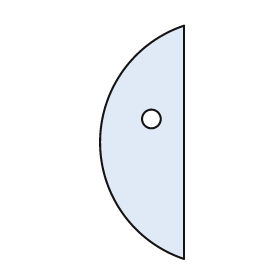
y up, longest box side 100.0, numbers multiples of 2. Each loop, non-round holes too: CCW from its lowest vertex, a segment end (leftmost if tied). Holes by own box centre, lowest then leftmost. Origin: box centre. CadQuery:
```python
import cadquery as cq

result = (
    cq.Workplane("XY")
    .moveTo(18.0, -50.0)
    .lineTo(18.0, 50.0)
    .threePointArc((-18.0, 0.0), (18.0, -50.0))
    .close()
    .moveTo(4.0, 10.0)
    .circle(4.0)
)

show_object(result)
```